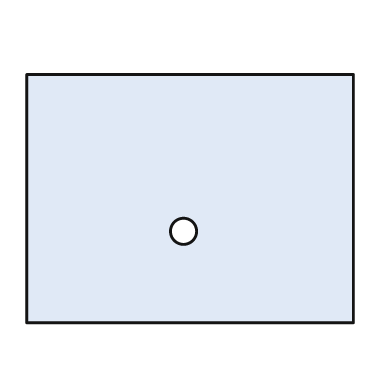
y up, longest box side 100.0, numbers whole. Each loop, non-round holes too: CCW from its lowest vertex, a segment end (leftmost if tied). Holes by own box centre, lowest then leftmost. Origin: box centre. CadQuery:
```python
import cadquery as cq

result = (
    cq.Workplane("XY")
    .moveTo(-50.0, -38.0)
    .lineTo(50.0, -38.0)
    .lineTo(50.0, 38.0)
    .lineTo(-50.0, 38.0)
    .close()
    .moveTo(-2.0, -10.0)
    .circle(4.0)
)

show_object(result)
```